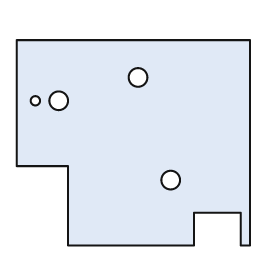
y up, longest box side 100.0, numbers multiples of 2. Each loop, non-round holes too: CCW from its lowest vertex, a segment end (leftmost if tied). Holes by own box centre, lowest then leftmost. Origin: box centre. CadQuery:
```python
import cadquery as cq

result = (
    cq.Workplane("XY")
    .moveTo(-28.0, -44.0)
    .lineTo(26.0, -44.0)
    .lineTo(26.0, -30.0)
    .lineTo(46.0, -30.0)
    .lineTo(46.0, -44.0)
    .lineTo(50.0, -44.0)
    .lineTo(50.0, 44.0)
    .lineTo(-50.0, 44.0)
    .lineTo(-50.0, -10.0)
    .lineTo(-28.0, -10.0)
    .close()
    .moveTo(16.0, -16.0)
    .circle(4.0)
    .moveTo(-42.0, 18.0)
    .circle(2.0)
    .moveTo(-32.0, 18.0)
    .circle(4.0)
    .moveTo(2.0, 28.0)
    .circle(4.0)
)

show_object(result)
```